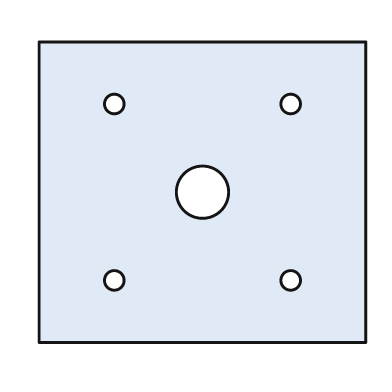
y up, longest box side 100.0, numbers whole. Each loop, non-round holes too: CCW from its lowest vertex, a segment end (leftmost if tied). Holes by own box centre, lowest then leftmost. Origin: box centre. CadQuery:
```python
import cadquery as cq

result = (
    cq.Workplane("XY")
    .moveTo(-50.0, -46.0)
    .lineTo(50.0, -46.0)
    .lineTo(50.0, 46.0)
    .lineTo(-50.0, 46.0)
    .close()
    .moveTo(-27.0, -27.0)
    .circle(3.0)
    .moveTo(27.0, -27.0)
    .circle(3.0)
    .moveTo(0.0, 0.0)
    .circle(8.0)
    .moveTo(-27.0, 27.0)
    .circle(3.0)
    .moveTo(27.0, 27.0)
    .circle(3.0)
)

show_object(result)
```